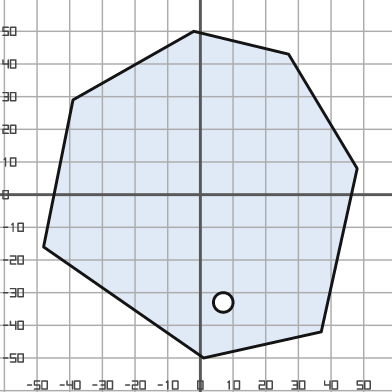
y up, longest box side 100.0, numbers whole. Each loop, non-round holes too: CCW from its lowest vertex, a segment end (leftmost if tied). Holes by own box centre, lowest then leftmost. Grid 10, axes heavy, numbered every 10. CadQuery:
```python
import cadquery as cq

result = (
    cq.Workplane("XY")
    .moveTo(1.0, -50.0)
    .lineTo(37.0, -42.0)
    .lineTo(48.0, 8.0)
    .lineTo(27.0, 43.0)
    .lineTo(-2.0, 50.0)
    .lineTo(-39.0, 29.0)
    .lineTo(-48.0, -16.0)
    .close()
    .moveTo(7.0, -33.0)
    .circle(3.0)
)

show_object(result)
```